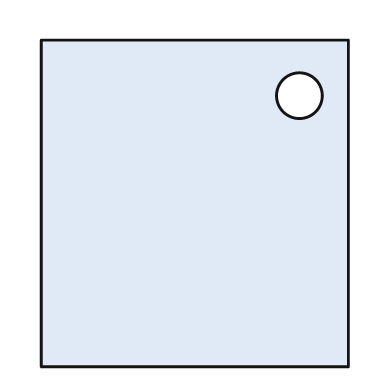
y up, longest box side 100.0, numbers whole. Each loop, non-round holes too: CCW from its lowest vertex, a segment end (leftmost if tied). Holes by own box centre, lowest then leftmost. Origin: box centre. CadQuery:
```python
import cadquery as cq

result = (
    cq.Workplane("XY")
    .moveTo(-47.0, -50.0)
    .lineTo(47.0, -50.0)
    .lineTo(47.0, 50.0)
    .lineTo(-47.0, 50.0)
    .close()
    .moveTo(32.0, 33.0)
    .circle(7.0)
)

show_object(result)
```